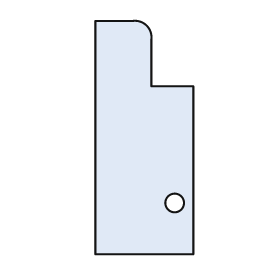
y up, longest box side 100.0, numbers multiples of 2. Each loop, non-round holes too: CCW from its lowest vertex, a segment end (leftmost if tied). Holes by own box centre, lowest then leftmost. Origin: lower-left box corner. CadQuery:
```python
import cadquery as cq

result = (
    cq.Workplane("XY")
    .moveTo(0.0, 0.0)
    .lineTo(42.0, 0.0)
    .lineTo(42.0, 72.0)
    .lineTo(24.0, 72.0)
    .lineTo(24.0, 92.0)
    .threePointArc((22.0, 98.0), (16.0, 100.0))
    .lineTo(0.0, 100.0)
    .close()
    .moveTo(34.0, 22.0)
    .circle(4.0)
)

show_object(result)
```